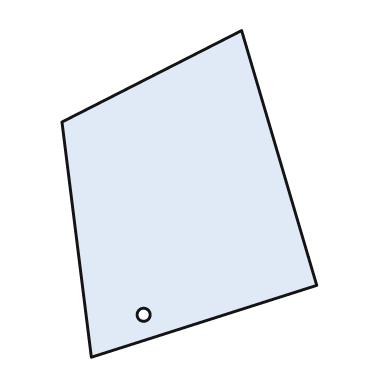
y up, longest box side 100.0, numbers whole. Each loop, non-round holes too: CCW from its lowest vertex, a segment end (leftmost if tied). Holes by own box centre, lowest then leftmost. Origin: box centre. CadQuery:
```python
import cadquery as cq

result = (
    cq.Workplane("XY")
    .moveTo(-30.0, -50.0)
    .lineTo(39.0, -28.0)
    .lineTo(16.0, 50.0)
    .lineTo(-39.0, 22.0)
    .close()
    .moveTo(-14.0, -37.0)
    .circle(2.0)
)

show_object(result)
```